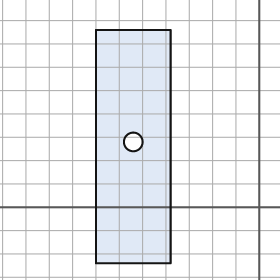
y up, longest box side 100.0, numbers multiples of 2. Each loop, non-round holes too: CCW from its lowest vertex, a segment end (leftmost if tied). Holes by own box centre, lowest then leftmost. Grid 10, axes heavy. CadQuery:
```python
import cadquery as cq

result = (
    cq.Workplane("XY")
    .moveTo(-70.0, -24.0)
    .lineTo(-38.0, -24.0)
    .lineTo(-38.0, 76.0)
    .lineTo(-70.0, 76.0)
    .close()
    .moveTo(-54.0, 28.0)
    .circle(4.0)
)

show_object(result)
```